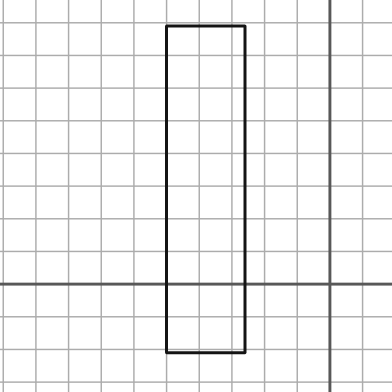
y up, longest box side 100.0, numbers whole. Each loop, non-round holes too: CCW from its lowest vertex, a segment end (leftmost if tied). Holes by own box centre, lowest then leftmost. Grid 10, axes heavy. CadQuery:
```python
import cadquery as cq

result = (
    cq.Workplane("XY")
    .moveTo(-50.0, -21.0)
    .lineTo(-26.0, -21.0)
    .lineTo(-26.0, 79.0)
    .lineTo(-50.0, 79.0)
    .close()
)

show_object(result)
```